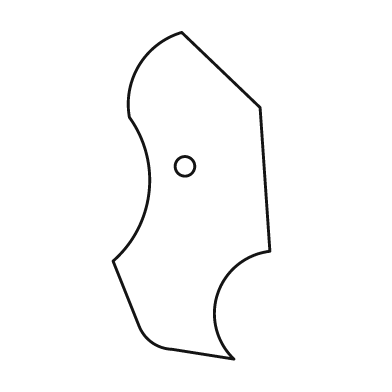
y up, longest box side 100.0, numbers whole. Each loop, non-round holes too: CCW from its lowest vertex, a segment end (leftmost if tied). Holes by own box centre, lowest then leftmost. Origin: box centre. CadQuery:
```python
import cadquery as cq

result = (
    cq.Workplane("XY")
    .moveTo(13.0, -50.0)
    .threePointArc((8.0, -30.0), (24.0, -17.0))
    .lineTo(21.0, 27.0)
    .lineTo(-3.0, 50.0)
    .threePointArc((-16.0, 40.0), (-19.0, 24.0))
    .threePointArc((-13.0, 1.0), (-24.0, -20.0))
    .lineTo(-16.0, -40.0)
    .threePointArc((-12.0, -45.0), (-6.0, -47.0))
    .close()
    .moveTo(-2.0, 9.0)
    .circle(3.0)
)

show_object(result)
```